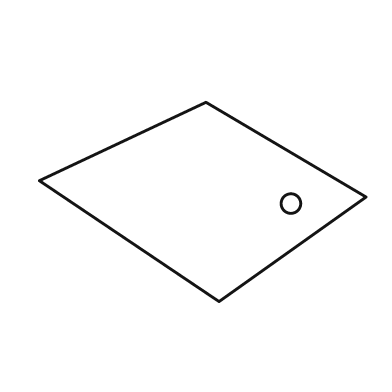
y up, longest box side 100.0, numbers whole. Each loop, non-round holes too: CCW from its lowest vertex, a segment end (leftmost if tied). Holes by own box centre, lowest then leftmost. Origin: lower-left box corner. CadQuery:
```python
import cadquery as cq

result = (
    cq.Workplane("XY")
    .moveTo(55.0, 0.0)
    .lineTo(100.0, 32.0)
    .lineTo(51.0, 61.0)
    .lineTo(0.0, 37.0)
    .close()
    .moveTo(77.0, 30.0)
    .circle(3.0)
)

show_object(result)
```